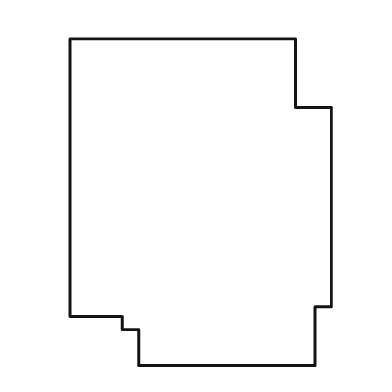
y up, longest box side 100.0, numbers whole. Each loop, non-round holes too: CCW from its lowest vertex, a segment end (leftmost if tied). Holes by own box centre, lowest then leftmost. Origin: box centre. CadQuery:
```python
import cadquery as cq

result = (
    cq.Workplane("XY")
    .moveTo(-19.0, -50.0)
    .lineTo(35.0, -50.0)
    .lineTo(35.0, -32.0)
    .lineTo(40.0, -32.0)
    .lineTo(40.0, 29.0)
    .lineTo(29.0, 29.0)
    .lineTo(29.0, 50.0)
    .lineTo(-40.0, 50.0)
    .lineTo(-40.0, -35.0)
    .lineTo(-24.0, -35.0)
    .lineTo(-24.0, -39.0)
    .lineTo(-19.0, -39.0)
    .close()
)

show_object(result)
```